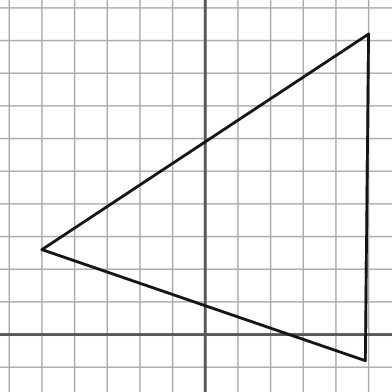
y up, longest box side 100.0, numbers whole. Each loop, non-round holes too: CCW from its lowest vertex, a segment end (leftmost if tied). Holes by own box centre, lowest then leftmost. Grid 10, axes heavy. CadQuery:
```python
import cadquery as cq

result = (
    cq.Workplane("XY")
    .moveTo(49.0, -8.0)
    .lineTo(50.0, 92.0)
    .lineTo(-50.0, 26.0)
    .close()
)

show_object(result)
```